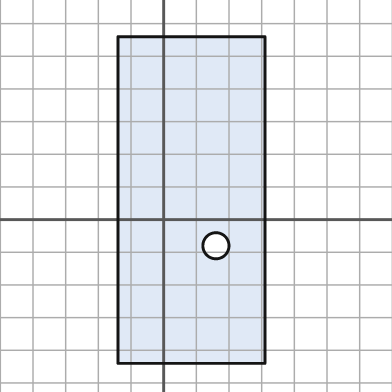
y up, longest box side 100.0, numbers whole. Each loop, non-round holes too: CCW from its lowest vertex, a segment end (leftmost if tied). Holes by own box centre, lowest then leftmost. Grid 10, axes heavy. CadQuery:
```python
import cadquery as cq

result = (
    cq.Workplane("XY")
    .moveTo(-14.0, -44.0)
    .lineTo(31.0, -44.0)
    .lineTo(31.0, 56.0)
    .lineTo(-14.0, 56.0)
    .close()
    .moveTo(16.0, -8.0)
    .circle(4.0)
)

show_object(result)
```